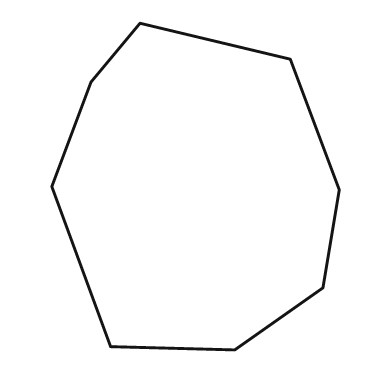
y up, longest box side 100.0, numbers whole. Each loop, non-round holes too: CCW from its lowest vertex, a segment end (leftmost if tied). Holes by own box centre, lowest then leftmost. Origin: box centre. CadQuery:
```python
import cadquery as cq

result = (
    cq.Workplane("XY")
    .moveTo(12.0, -50.0)
    .lineTo(39.0, -31.0)
    .lineTo(44.0, -1.0)
    .lineTo(29.0, 39.0)
    .lineTo(-17.0, 50.0)
    .lineTo(-32.0, 32.0)
    .lineTo(-44.0, 0.0)
    .lineTo(-26.0, -49.0)
    .close()
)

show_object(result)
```